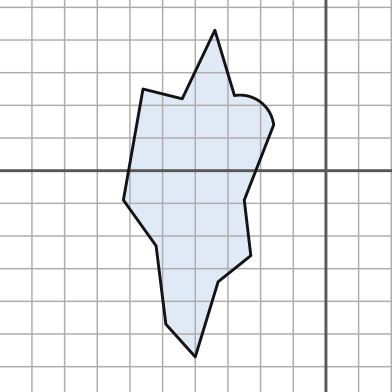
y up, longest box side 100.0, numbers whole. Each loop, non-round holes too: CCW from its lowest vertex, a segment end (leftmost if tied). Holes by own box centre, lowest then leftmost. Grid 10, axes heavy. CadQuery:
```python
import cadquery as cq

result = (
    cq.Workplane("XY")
    .moveTo(-40.0, -57.0)
    .lineTo(-33.0, -34.0)
    .lineTo(-23.0, -26.0)
    .lineTo(-25.0, -9.0)
    .lineTo(-16.0, 14.0)
    .threePointArc((-20.0, 21.0), (-28.0, 23.0))
    .lineTo(-34.0, 43.0)
    .lineTo(-44.0, 22.0)
    .lineTo(-56.0, 25.0)
    .lineTo(-62.0, -9.0)
    .lineTo(-52.0, -23.0)
    .lineTo(-49.0, -47.0)
    .close()
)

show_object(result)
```